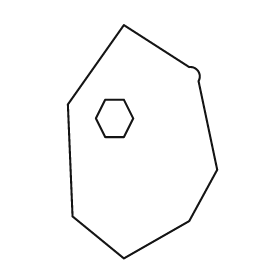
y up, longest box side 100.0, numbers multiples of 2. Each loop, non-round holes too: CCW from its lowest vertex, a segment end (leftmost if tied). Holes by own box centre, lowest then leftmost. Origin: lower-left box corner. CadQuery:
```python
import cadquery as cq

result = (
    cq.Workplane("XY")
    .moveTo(24.0, 0.0)
    .lineTo(52.0, 16.0)
    .lineTo(64.0, 38.0)
    .lineTo(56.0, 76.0)
    .threePointArc((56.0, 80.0), (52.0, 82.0))
    .lineTo(24.0, 100.0)
    .lineTo(0.0, 66.0)
    .lineTo(2.0, 18.0)
    .close()
    .moveTo(16.0, 52.0)
    .lineTo(24.0, 52.0)
    .lineTo(28.0, 60.0)
    .lineTo(24.0, 68.0)
    .lineTo(16.0, 68.0)
    .lineTo(12.0, 60.0)
    .close()
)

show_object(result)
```